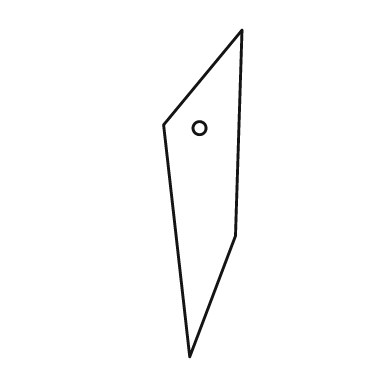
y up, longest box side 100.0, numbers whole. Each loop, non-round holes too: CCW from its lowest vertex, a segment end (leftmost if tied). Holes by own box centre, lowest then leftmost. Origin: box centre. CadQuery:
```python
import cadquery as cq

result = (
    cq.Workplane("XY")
    .moveTo(-4.0, -50.0)
    .lineTo(10.0, -13.0)
    .lineTo(12.0, 50.0)
    .lineTo(-12.0, 21.0)
    .close()
    .moveTo(-1.0, 20.0)
    .circle(2.0)
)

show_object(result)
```